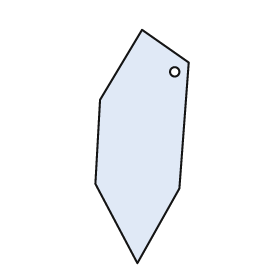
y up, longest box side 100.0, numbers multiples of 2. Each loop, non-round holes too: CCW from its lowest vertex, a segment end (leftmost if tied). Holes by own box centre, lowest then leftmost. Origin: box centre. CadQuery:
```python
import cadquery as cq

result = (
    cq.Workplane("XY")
    .moveTo(-2.0, -50.0)
    .lineTo(16.0, -18.0)
    .lineTo(20.0, 36.0)
    .lineTo(0.0, 50.0)
    .lineTo(-18.0, 20.0)
    .lineTo(-20.0, -16.0)
    .close()
    .moveTo(14.0, 32.0)
    .circle(2.0)
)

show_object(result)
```